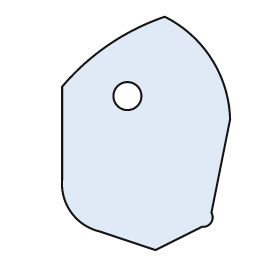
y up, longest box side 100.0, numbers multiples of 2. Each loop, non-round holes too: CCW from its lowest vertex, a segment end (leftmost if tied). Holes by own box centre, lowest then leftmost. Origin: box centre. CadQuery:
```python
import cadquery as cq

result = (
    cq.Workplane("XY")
    .moveTo(4.0, -50.0)
    .lineTo(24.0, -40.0)
    .threePointArc((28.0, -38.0), (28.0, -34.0))
    .lineTo(36.0, 6.0)
    .threePointArc((28.0, 32.0), (8.0, 50.0))
    .threePointArc((-16.0, 38.0), (-36.0, 20.0))
    .lineTo(-36.0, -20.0)
    .threePointArc((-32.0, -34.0), (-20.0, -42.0))
    .close()
    .moveTo(-8.0, 16.0)
    .circle(6.0)
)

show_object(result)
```